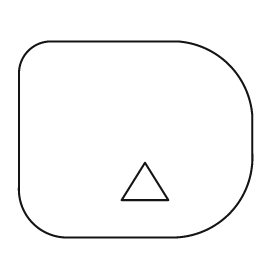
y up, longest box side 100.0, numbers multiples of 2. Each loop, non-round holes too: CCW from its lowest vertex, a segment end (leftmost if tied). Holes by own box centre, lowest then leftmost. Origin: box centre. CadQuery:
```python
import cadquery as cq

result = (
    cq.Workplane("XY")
    .moveTo(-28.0, -42.0)
    .lineTo(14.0, -42.0)
    .threePointArc((40.0, -32.0), (50.0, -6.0))
    .lineTo(50.0, 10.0)
    .threePointArc((40.0, 32.0), (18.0, 42.0))
    .lineTo(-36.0, 42.0)
    .threePointArc((-46.0, 38.0), (-50.0, 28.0))
    .lineTo(-50.0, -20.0)
    .threePointArc((-44.0, -36.0), (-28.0, -42.0))
    .close()
    .moveTo(-6.0, -26.0)
    .lineTo(14.0, -26.0)
    .lineTo(4.0, -10.0)
    .close()
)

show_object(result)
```